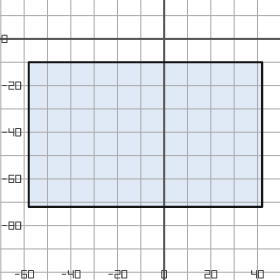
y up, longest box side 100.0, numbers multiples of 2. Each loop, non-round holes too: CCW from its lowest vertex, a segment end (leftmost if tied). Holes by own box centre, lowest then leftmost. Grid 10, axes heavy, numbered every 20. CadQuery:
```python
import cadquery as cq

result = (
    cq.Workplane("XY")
    .moveTo(-58.0, -72.0)
    .lineTo(42.0, -72.0)
    .lineTo(42.0, -10.0)
    .lineTo(-58.0, -10.0)
    .close()
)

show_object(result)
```